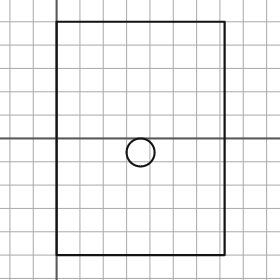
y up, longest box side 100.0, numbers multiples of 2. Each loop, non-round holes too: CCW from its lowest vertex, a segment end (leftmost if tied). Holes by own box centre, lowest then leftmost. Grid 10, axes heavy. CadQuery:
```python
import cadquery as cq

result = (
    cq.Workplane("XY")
    .moveTo(0.0, -50.0)
    .lineTo(72.0, -50.0)
    .lineTo(72.0, 50.0)
    .lineTo(0.0, 50.0)
    .close()
    .moveTo(36.0, -6.0)
    .circle(6.0)
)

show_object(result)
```